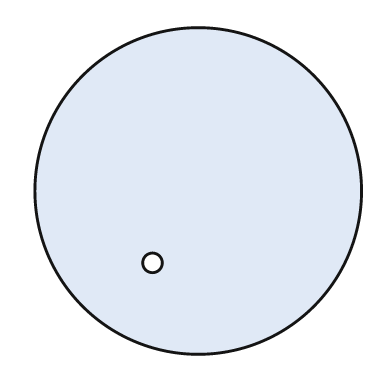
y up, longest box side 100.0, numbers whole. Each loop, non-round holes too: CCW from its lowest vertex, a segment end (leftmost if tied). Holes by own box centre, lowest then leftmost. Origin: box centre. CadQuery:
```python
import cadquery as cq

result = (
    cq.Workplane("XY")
    .moveTo(0.0, 0.0)
    .circle(50.0)
    .moveTo(-14.0, -22.0)
    .circle(3.0)
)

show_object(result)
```